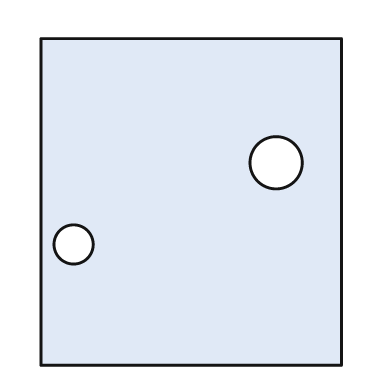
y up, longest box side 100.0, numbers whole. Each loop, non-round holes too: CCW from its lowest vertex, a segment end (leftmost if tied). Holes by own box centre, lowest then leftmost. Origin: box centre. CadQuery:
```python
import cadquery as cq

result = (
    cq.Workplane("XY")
    .moveTo(-46.0, -50.0)
    .lineTo(46.0, -50.0)
    .lineTo(46.0, 50.0)
    .lineTo(-46.0, 50.0)
    .close()
    .moveTo(-36.0, -13.0)
    .circle(6.0)
    .moveTo(26.0, 12.0)
    .circle(8.0)
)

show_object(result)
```